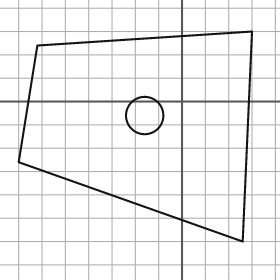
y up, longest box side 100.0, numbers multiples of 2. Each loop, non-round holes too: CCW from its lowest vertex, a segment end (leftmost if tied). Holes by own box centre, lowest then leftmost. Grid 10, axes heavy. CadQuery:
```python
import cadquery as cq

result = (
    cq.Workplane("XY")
    .moveTo(26.0, -60.0)
    .lineTo(30.0, 30.0)
    .lineTo(-62.0, 24.0)
    .lineTo(-70.0, -26.0)
    .close()
    .moveTo(-16.0, -6.0)
    .circle(8.0)
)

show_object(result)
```